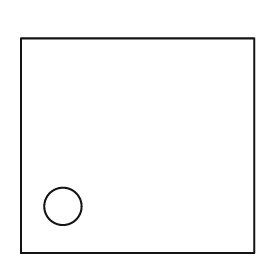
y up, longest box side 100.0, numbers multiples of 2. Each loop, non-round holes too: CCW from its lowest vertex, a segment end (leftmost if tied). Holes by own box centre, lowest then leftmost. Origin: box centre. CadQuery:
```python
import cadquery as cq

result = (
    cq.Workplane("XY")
    .moveTo(-50.0, -46.0)
    .lineTo(50.0, -46.0)
    .lineTo(50.0, 46.0)
    .lineTo(-50.0, 46.0)
    .close()
    .moveTo(-32.0, -26.0)
    .circle(8.0)
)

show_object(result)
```